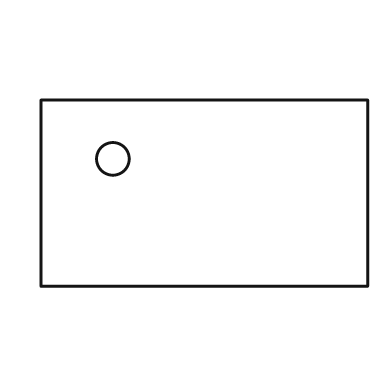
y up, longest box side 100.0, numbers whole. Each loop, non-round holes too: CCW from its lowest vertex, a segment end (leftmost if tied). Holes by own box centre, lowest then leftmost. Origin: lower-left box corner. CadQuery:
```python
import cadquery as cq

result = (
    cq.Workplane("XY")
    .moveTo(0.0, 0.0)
    .lineTo(100.0, 0.0)
    .lineTo(100.0, 57.0)
    .lineTo(0.0, 57.0)
    .close()
    .moveTo(22.0, 39.0)
    .circle(5.0)
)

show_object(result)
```